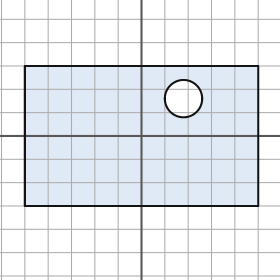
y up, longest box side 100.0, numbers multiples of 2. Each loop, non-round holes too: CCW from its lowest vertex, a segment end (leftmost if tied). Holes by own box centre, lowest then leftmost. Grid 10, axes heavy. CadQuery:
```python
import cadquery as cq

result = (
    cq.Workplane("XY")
    .moveTo(-50.0, -30.0)
    .lineTo(50.0, -30.0)
    .lineTo(50.0, 30.0)
    .lineTo(-50.0, 30.0)
    .close()
    .moveTo(18.0, 16.0)
    .circle(8.0)
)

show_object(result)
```